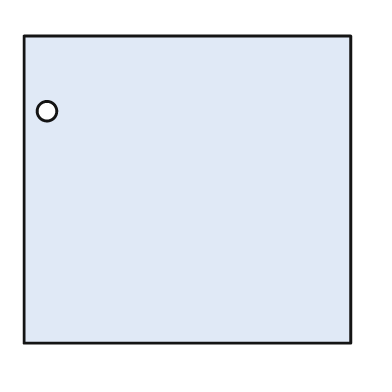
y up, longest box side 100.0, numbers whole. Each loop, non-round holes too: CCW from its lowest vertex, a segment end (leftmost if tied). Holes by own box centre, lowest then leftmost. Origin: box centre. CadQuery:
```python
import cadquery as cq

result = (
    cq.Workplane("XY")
    .moveTo(-50.0, -47.0)
    .lineTo(50.0, -47.0)
    .lineTo(50.0, 47.0)
    .lineTo(-50.0, 47.0)
    .close()
    .moveTo(-43.0, 24.0)
    .circle(3.0)
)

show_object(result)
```